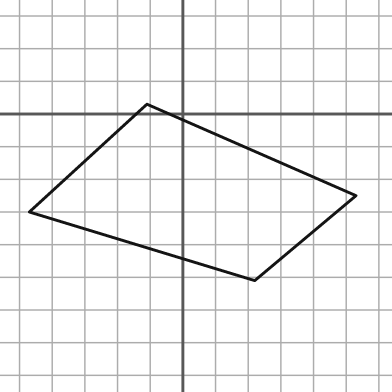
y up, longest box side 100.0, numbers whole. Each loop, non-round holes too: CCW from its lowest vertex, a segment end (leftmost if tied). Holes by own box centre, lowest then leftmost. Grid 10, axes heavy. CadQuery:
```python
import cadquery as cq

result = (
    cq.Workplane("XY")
    .moveTo(22.0, -51.0)
    .lineTo(53.0, -25.0)
    .lineTo(-11.0, 3.0)
    .lineTo(-47.0, -30.0)
    .close()
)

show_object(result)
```